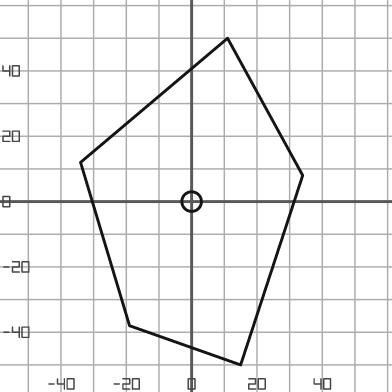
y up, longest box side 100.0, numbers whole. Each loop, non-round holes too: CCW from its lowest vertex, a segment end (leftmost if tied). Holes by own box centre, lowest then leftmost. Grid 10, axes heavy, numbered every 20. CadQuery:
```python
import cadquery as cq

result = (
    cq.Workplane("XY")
    .moveTo(15.0, -50.0)
    .lineTo(34.0, 8.0)
    .lineTo(11.0, 50.0)
    .lineTo(-34.0, 12.0)
    .lineTo(-19.0, -38.0)
    .close()
    .moveTo(0.0, 0.0)
    .circle(3.0)
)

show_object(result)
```